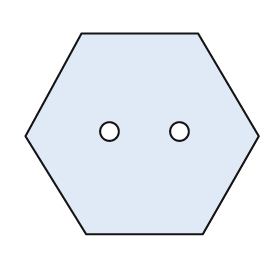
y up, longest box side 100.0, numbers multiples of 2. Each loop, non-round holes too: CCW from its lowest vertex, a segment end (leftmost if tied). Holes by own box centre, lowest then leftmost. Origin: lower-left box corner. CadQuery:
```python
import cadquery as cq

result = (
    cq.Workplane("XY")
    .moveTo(26.0, 0.0)
    .lineTo(76.0, 0.0)
    .lineTo(100.0, 42.0)
    .lineTo(74.0, 86.0)
    .lineTo(24.0, 86.0)
    .lineTo(0.0, 42.0)
    .close()
    .moveTo(36.0, 44.0)
    .circle(4.0)
    .moveTo(66.0, 44.0)
    .circle(4.0)
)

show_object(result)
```